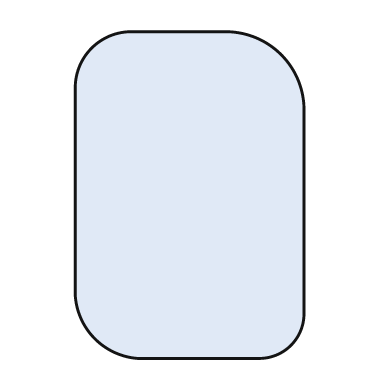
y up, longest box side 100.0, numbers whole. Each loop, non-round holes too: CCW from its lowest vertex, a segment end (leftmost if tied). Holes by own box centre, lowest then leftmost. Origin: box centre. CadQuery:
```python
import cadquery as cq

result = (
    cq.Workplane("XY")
    .moveTo(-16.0, -50.0)
    .lineTo(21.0, -50.0)
    .threePointArc((31.0, -46.0), (35.0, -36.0))
    .lineTo(35.0, 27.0)
    .threePointArc((28.0, 43.0), (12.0, 50.0))
    .lineTo(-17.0, 50.0)
    .threePointArc((-30.0, 45.0), (-35.0, 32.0))
    .lineTo(-35.0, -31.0)
    .threePointArc((-29.0, -44.0), (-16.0, -50.0))
    .close()
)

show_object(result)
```